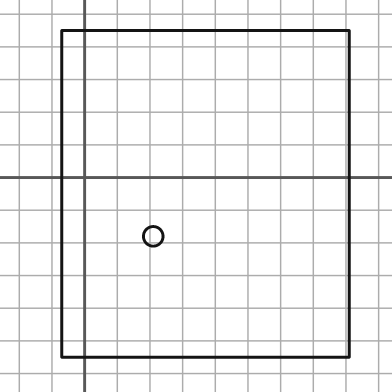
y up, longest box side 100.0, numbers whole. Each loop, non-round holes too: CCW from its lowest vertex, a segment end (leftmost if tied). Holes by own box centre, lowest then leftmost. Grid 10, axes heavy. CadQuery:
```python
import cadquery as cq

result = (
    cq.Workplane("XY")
    .moveTo(-7.0, -55.0)
    .lineTo(81.0, -55.0)
    .lineTo(81.0, 45.0)
    .lineTo(-7.0, 45.0)
    .close()
    .moveTo(21.0, -18.0)
    .circle(3.0)
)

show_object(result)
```